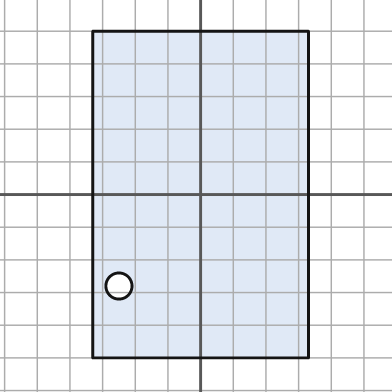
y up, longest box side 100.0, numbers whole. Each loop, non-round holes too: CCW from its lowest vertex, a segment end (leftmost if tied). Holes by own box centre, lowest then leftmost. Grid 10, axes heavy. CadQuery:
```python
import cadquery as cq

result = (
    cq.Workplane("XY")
    .moveTo(-33.0, -50.0)
    .lineTo(33.0, -50.0)
    .lineTo(33.0, 50.0)
    .lineTo(-33.0, 50.0)
    .close()
    .moveTo(-25.0, -28.0)
    .circle(4.0)
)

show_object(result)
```